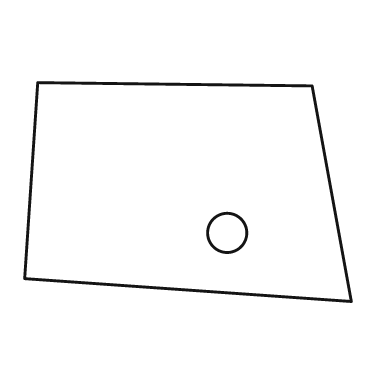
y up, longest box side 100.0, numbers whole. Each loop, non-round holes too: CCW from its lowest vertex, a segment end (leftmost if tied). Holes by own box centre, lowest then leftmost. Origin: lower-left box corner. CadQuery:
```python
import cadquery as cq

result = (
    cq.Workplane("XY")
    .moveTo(100.0, 0.0)
    .lineTo(88.0, 66.0)
    .lineTo(4.0, 67.0)
    .lineTo(0.0, 7.0)
    .close()
    .moveTo(62.0, 21.0)
    .circle(6.0)
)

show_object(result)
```